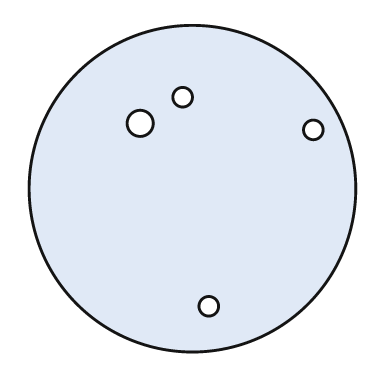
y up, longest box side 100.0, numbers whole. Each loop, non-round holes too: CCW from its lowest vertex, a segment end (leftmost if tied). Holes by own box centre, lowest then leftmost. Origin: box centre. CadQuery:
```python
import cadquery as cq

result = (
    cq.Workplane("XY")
    .moveTo(0.0, 0.0)
    .circle(50.0)
    .moveTo(5.0, -36.0)
    .circle(3.0)
    .moveTo(37.0, 18.0)
    .circle(3.0)
    .moveTo(-16.0, 20.0)
    .circle(4.0)
    .moveTo(-3.0, 28.0)
    .circle(3.0)
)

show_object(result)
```